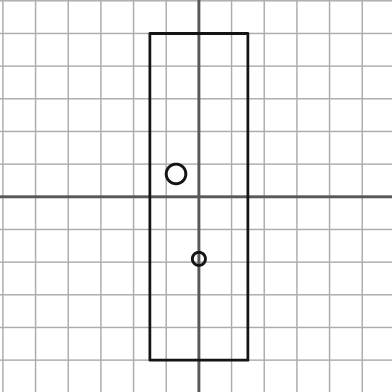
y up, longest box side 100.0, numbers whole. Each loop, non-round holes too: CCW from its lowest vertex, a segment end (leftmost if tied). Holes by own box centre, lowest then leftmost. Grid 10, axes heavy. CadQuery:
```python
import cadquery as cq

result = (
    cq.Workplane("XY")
    .moveTo(-15.0, -50.0)
    .lineTo(15.0, -50.0)
    .lineTo(15.0, 50.0)
    .lineTo(-15.0, 50.0)
    .close()
    .moveTo(0.0, -19.0)
    .circle(2.0)
    .moveTo(-7.0, 7.0)
    .circle(3.0)
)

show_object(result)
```